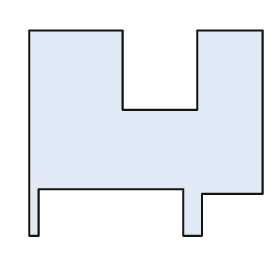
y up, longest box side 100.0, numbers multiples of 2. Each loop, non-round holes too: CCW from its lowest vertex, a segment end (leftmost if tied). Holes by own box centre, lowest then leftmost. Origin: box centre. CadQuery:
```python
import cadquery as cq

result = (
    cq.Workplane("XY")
    .moveTo(-50.0, -44.0)
    .lineTo(-46.0, -44.0)
    .lineTo(-46.0, -24.0)
    .lineTo(16.0, -24.0)
    .lineTo(16.0, -44.0)
    .lineTo(24.0, -44.0)
    .lineTo(24.0, -26.0)
    .lineTo(50.0, -26.0)
    .lineTo(50.0, 44.0)
    .lineTo(22.0, 44.0)
    .lineTo(22.0, 10.0)
    .lineTo(-10.0, 10.0)
    .lineTo(-10.0, 44.0)
    .lineTo(-50.0, 44.0)
    .close()
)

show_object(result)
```